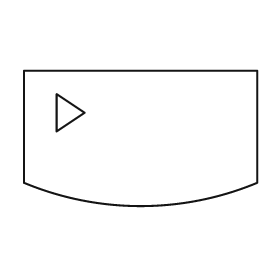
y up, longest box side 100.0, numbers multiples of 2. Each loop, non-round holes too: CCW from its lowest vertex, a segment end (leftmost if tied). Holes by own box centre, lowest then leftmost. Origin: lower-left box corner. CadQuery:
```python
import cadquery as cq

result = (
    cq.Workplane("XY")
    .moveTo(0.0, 10.0)
    .threePointArc((50.0, 0.0), (100.0, 10.0))
    .lineTo(100.0, 58.0)
    .lineTo(0.0, 58.0)
    .close()
    .moveTo(14.0, 32.0)
    .lineTo(26.0, 40.0)
    .lineTo(14.0, 48.0)
    .close()
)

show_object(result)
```